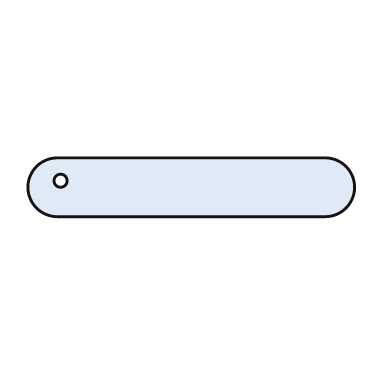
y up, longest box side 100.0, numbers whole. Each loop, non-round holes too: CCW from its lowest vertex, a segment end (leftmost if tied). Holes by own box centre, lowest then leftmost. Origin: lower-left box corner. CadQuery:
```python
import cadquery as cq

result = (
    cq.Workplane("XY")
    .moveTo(9.0, 0.0)
    .lineTo(91.0, 0.0)
    .threePointArc((100.0, 9.0), (91.0, 18.0))
    .lineTo(9.0, 18.0)
    .threePointArc((0.0, 9.0), (9.0, 0.0))
    .close()
    .moveTo(10.0, 11.0)
    .circle(2.0)
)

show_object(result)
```